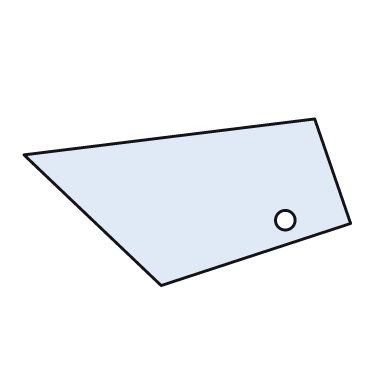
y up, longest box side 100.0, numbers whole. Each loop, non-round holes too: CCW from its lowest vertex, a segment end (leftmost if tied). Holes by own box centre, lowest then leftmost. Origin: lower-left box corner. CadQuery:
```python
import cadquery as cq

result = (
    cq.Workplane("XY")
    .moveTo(42.0, 0.0)
    .lineTo(100.0, 19.0)
    .lineTo(89.0, 51.0)
    .lineTo(0.0, 40.0)
    .close()
    .moveTo(80.0, 20.0)
    .circle(3.0)
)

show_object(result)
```